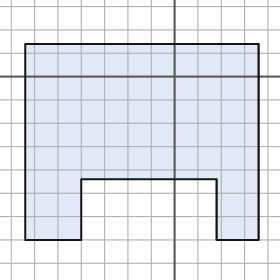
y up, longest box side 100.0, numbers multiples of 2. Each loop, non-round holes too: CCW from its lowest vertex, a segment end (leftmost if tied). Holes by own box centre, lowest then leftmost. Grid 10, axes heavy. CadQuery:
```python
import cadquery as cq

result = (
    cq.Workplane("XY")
    .moveTo(-64.0, -70.0)
    .lineTo(-40.0, -70.0)
    .lineTo(-40.0, -44.0)
    .lineTo(18.0, -44.0)
    .lineTo(18.0, -70.0)
    .lineTo(36.0, -70.0)
    .lineTo(36.0, 14.0)
    .lineTo(-64.0, 14.0)
    .close()
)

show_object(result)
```